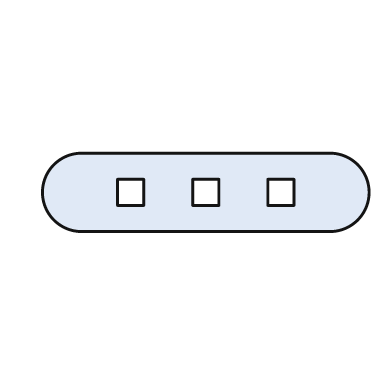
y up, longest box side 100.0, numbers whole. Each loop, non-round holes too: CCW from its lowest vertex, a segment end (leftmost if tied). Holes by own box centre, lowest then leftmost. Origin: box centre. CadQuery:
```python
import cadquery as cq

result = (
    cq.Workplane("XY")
    .moveTo(-38.0, -12.0)
    .lineTo(38.0, -12.0)
    .threePointArc((50.0, 0.0), (38.0, 12.0))
    .lineTo(-38.0, 12.0)
    .threePointArc((-50.0, 0.0), (-38.0, -12.0))
    .close()
    .moveTo(-27.0, -4.0)
    .lineTo(-19.0, -4.0)
    .lineTo(-19.0, 4.0)
    .lineTo(-27.0, 4.0)
    .close()
    .moveTo(-4.0, -4.0)
    .lineTo(4.0, -4.0)
    .lineTo(4.0, 4.0)
    .lineTo(-4.0, 4.0)
    .close()
    .moveTo(19.0, -4.0)
    .lineTo(27.0, -4.0)
    .lineTo(27.0, 4.0)
    .lineTo(19.0, 4.0)
    .close()
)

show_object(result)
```